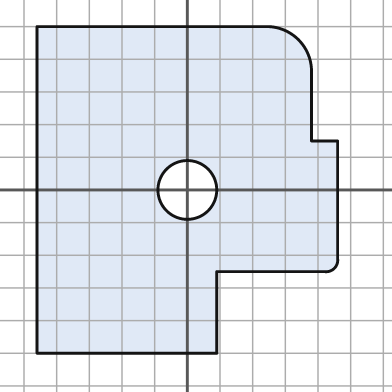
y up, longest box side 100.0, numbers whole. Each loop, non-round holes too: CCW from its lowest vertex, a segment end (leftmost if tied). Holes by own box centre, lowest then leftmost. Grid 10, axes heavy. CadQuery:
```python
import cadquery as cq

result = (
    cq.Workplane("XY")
    .moveTo(-46.0, -50.0)
    .lineTo(9.0, -50.0)
    .lineTo(9.0, -25.0)
    .lineTo(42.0, -25.0)
    .threePointArc((45.0, -24.0), (46.0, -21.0))
    .lineTo(46.0, 15.0)
    .lineTo(38.0, 15.0)
    .lineTo(38.0, 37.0)
    .threePointArc((34.0, 46.0), (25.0, 50.0))
    .lineTo(-46.0, 50.0)
    .close()
    .moveTo(0.0, 0.0)
    .circle(9.0)
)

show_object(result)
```